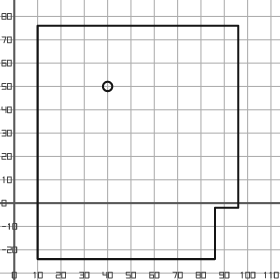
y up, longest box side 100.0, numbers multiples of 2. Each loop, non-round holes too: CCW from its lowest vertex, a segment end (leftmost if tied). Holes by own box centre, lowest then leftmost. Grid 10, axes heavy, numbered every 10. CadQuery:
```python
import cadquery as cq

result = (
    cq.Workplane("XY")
    .moveTo(10.0, -24.0)
    .lineTo(86.0, -24.0)
    .lineTo(86.0, -2.0)
    .lineTo(96.0, -2.0)
    .lineTo(96.0, 76.0)
    .lineTo(10.0, 76.0)
    .close()
    .moveTo(40.0, 50.0)
    .circle(2.0)
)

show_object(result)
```